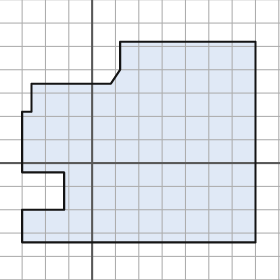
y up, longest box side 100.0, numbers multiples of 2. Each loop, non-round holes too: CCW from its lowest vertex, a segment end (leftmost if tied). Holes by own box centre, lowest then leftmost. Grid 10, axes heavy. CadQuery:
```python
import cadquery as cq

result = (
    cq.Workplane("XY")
    .moveTo(-30.0, -34.0)
    .lineTo(70.0, -34.0)
    .lineTo(70.0, 52.0)
    .lineTo(12.0, 52.0)
    .lineTo(12.0, 40.0)
    .lineTo(8.0, 34.0)
    .lineTo(-26.0, 34.0)
    .lineTo(-26.0, 22.0)
    .lineTo(-30.0, 22.0)
    .lineTo(-30.0, -4.0)
    .lineTo(-12.0, -4.0)
    .lineTo(-12.0, -20.0)
    .lineTo(-30.0, -20.0)
    .close()
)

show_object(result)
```